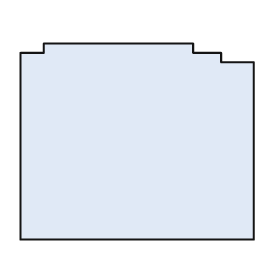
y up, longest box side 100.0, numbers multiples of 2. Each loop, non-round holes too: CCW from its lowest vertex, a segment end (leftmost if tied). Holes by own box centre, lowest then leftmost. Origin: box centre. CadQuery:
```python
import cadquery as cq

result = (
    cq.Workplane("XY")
    .moveTo(-50.0, -42.0)
    .lineTo(50.0, -42.0)
    .lineTo(50.0, 34.0)
    .lineTo(36.0, 34.0)
    .lineTo(36.0, 38.0)
    .lineTo(24.0, 38.0)
    .lineTo(24.0, 42.0)
    .lineTo(-40.0, 42.0)
    .lineTo(-40.0, 38.0)
    .lineTo(-50.0, 38.0)
    .close()
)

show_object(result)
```